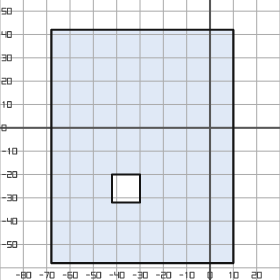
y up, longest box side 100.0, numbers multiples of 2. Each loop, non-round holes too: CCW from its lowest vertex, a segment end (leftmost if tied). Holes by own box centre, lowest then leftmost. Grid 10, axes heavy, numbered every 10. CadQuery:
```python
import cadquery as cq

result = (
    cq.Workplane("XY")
    .moveTo(-68.0, -58.0)
    .lineTo(10.0, -58.0)
    .lineTo(10.0, 42.0)
    .lineTo(-68.0, 42.0)
    .close()
    .moveTo(-42.0, -32.0)
    .lineTo(-30.0, -32.0)
    .lineTo(-30.0, -20.0)
    .lineTo(-42.0, -20.0)
    .close()
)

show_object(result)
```